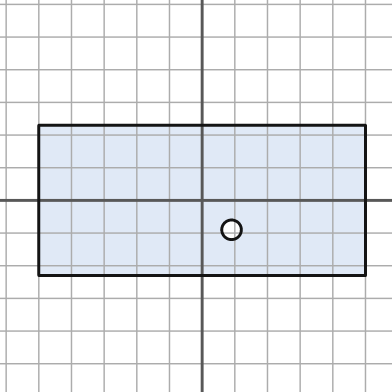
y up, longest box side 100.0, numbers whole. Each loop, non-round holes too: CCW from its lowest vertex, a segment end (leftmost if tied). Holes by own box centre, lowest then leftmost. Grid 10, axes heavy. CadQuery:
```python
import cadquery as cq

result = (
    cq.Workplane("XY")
    .moveTo(-50.0, -23.0)
    .lineTo(50.0, -23.0)
    .lineTo(50.0, 23.0)
    .lineTo(-50.0, 23.0)
    .close()
    .moveTo(9.0, -9.0)
    .circle(3.0)
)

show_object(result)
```